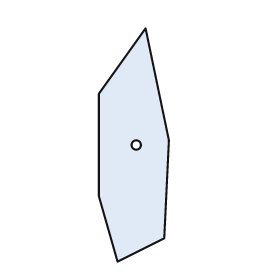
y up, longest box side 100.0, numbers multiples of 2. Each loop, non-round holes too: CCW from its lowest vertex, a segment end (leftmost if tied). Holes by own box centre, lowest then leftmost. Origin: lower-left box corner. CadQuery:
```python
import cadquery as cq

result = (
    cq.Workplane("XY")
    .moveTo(8.0, 0.0)
    .lineTo(28.0, 10.0)
    .lineTo(30.0, 52.0)
    .lineTo(20.0, 100.0)
    .lineTo(0.0, 72.0)
    .lineTo(0.0, 28.0)
    .close()
    .moveTo(16.0, 50.0)
    .circle(2.0)
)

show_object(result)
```